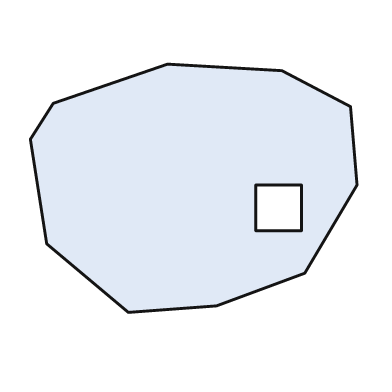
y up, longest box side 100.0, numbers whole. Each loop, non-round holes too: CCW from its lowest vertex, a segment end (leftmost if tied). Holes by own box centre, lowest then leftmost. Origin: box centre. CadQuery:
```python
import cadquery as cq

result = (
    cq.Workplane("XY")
    .moveTo(-20.0, -38.0)
    .lineTo(7.0, -36.0)
    .lineTo(34.0, -26.0)
    .lineTo(50.0, 1.0)
    .lineTo(48.0, 25.0)
    .lineTo(27.0, 36.0)
    .lineTo(-8.0, 38.0)
    .lineTo(-43.0, 26.0)
    .lineTo(-50.0, 15.0)
    .lineTo(-45.0, -17.0)
    .close()
    .moveTo(19.0, -13.0)
    .lineTo(33.0, -13.0)
    .lineTo(33.0, 1.0)
    .lineTo(19.0, 1.0)
    .close()
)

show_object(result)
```